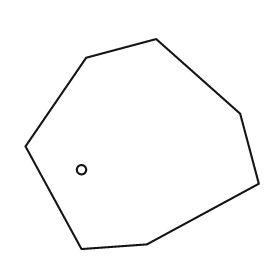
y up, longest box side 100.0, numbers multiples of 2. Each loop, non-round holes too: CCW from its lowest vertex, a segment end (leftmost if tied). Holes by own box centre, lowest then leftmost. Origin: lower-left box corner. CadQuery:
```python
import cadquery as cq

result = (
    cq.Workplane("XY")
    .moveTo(24.0, 0.0)
    .lineTo(52.0, 2.0)
    .lineTo(100.0, 28.0)
    .lineTo(92.0, 58.0)
    .lineTo(56.0, 90.0)
    .lineTo(26.0, 82.0)
    .lineTo(0.0, 44.0)
    .close()
    .moveTo(24.0, 34.0)
    .circle(2.0)
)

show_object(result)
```